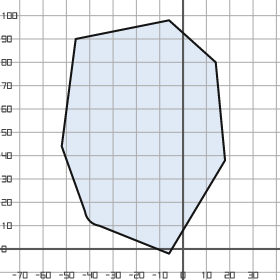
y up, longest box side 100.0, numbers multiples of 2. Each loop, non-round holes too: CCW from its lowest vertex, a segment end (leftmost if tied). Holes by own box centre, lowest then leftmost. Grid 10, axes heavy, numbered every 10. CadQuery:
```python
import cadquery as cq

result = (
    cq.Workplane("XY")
    .moveTo(-6.0, -2.0)
    .lineTo(18.0, 38.0)
    .lineTo(14.0, 80.0)
    .lineTo(-6.0, 98.0)
    .lineTo(-46.0, 90.0)
    .lineTo(-52.0, 44.0)
    .lineTo(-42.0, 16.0)
    .threePointArc((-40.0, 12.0), (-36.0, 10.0))
    .close()
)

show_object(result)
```